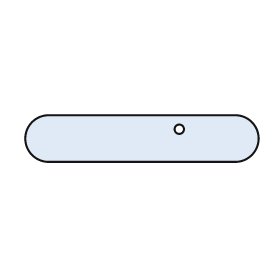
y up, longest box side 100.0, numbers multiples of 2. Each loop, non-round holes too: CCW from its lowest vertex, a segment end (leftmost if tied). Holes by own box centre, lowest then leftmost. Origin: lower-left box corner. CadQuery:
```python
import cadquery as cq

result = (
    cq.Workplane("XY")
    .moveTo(10.0, 0.0)
    .lineTo(90.0, 0.0)
    .threePointArc((100.0, 10.0), (90.0, 20.0))
    .lineTo(10.0, 20.0)
    .threePointArc((0.0, 10.0), (10.0, 0.0))
    .close()
    .moveTo(66.0, 14.0)
    .circle(2.0)
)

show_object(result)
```